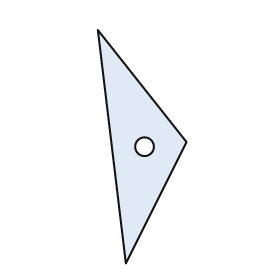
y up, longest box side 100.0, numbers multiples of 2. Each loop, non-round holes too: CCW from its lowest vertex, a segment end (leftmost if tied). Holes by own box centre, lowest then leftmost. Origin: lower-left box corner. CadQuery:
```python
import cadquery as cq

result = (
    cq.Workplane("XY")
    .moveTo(12.0, 0.0)
    .lineTo(38.0, 52.0)
    .lineTo(0.0, 100.0)
    .close()
    .moveTo(20.0, 50.0)
    .circle(4.0)
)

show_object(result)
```